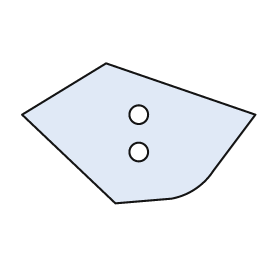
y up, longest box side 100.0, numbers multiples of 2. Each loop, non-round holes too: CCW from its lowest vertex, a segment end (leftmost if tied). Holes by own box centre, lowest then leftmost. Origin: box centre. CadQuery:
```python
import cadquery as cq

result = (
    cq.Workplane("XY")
    .moveTo(-10.0, -30.0)
    .lineTo(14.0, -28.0)
    .threePointArc((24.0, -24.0), (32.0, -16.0))
    .lineTo(50.0, 8.0)
    .lineTo(-14.0, 30.0)
    .lineTo(-50.0, 8.0)
    .close()
    .moveTo(0.0, -8.0)
    .circle(4.0)
    .moveTo(0.0, 8.0)
    .circle(4.0)
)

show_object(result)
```